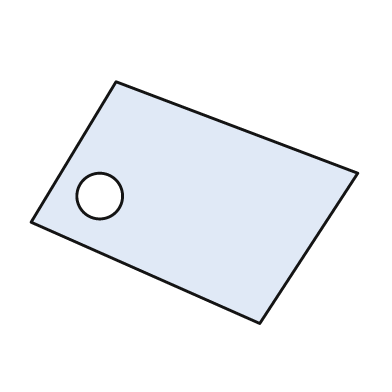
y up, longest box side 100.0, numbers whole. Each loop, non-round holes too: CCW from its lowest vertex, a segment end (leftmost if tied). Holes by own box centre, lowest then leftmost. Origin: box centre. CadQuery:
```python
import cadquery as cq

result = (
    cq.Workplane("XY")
    .moveTo(20.0, -37.0)
    .lineTo(50.0, 9.0)
    .lineTo(-24.0, 37.0)
    .lineTo(-50.0, -6.0)
    .close()
    .moveTo(-29.0, 2.0)
    .circle(7.0)
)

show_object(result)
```